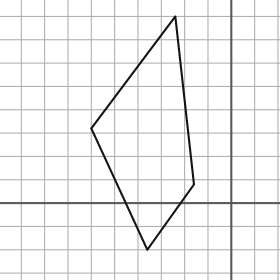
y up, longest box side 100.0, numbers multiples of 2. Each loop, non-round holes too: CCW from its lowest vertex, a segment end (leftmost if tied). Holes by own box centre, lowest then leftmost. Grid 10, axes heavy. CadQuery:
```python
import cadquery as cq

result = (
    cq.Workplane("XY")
    .moveTo(-36.0, -20.0)
    .lineTo(-16.0, 8.0)
    .lineTo(-24.0, 80.0)
    .lineTo(-60.0, 32.0)
    .close()
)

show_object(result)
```